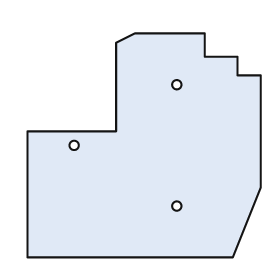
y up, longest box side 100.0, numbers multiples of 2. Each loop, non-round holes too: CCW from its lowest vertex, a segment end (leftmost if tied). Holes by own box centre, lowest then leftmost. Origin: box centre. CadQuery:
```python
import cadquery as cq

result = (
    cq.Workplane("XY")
    .moveTo(-50.0, -48.0)
    .lineTo(38.0, -48.0)
    .lineTo(50.0, -18.0)
    .lineTo(50.0, 30.0)
    .lineTo(40.0, 30.0)
    .lineTo(40.0, 38.0)
    .lineTo(26.0, 38.0)
    .lineTo(26.0, 48.0)
    .lineTo(-4.0, 48.0)
    .lineTo(-12.0, 44.0)
    .lineTo(-12.0, 6.0)
    .lineTo(-50.0, 6.0)
    .close()
    .moveTo(14.0, -26.0)
    .circle(2.0)
    .moveTo(-30.0, 0.0)
    .circle(2.0)
    .moveTo(14.0, 26.0)
    .circle(2.0)
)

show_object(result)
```